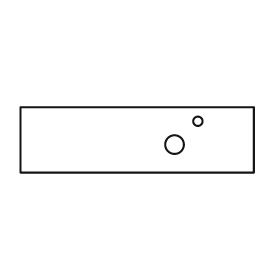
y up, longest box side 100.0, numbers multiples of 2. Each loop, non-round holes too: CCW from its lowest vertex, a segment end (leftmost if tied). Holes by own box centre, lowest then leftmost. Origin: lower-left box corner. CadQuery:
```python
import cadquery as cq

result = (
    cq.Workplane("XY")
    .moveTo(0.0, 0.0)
    .lineTo(100.0, 0.0)
    .lineTo(100.0, 28.0)
    .lineTo(0.0, 28.0)
    .close()
    .moveTo(66.0, 12.0)
    .circle(4.0)
    .moveTo(76.0, 22.0)
    .circle(2.0)
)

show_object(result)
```